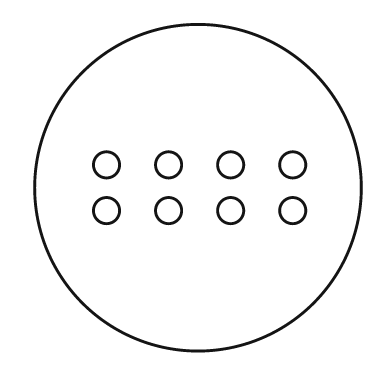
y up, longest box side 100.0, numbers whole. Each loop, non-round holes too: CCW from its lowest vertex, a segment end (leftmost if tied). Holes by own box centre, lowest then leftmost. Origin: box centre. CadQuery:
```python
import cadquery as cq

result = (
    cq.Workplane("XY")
    .moveTo(0.0, 0.0)
    .circle(50.0)
    .moveTo(-28.0, -7.0)
    .circle(4.0)
    .moveTo(-9.0, -7.0)
    .circle(4.0)
    .moveTo(10.0, -7.0)
    .circle(4.0)
    .moveTo(29.0, -7.0)
    .circle(4.0)
    .moveTo(-28.0, 7.0)
    .circle(4.0)
    .moveTo(-9.0, 7.0)
    .circle(4.0)
    .moveTo(10.0, 7.0)
    .circle(4.0)
    .moveTo(29.0, 7.0)
    .circle(4.0)
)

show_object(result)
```